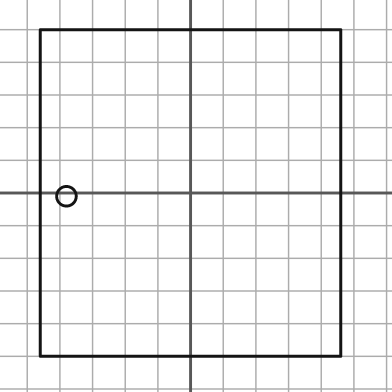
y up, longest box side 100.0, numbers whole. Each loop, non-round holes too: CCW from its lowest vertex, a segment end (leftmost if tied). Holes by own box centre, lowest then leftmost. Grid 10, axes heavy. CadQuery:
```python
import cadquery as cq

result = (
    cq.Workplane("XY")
    .moveTo(-46.0, -50.0)
    .lineTo(46.0, -50.0)
    .lineTo(46.0, 50.0)
    .lineTo(-46.0, 50.0)
    .close()
    .moveTo(-38.0, -1.0)
    .circle(3.0)
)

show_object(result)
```